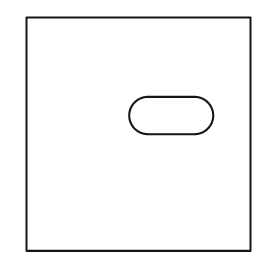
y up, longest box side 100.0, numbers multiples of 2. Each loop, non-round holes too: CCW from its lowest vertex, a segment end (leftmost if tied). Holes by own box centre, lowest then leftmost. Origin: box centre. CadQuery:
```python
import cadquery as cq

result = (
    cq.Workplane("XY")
    .moveTo(-48.0, -50.0)
    .lineTo(48.0, -50.0)
    .lineTo(48.0, 50.0)
    .lineTo(-48.0, 50.0)
    .close()
    .moveTo(4.0, 0.0)
    .lineTo(24.0, 0.0)
    .threePointArc((32.0, 8.0), (24.0, 16.0))
    .lineTo(4.0, 16.0)
    .threePointArc((-4.0, 8.0), (4.0, 0.0))
    .close()
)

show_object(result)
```